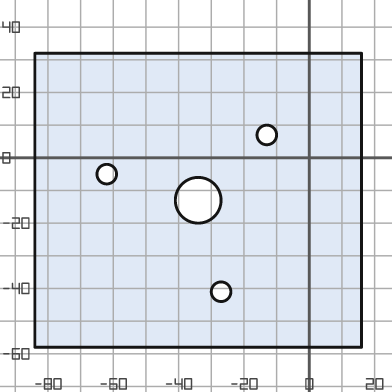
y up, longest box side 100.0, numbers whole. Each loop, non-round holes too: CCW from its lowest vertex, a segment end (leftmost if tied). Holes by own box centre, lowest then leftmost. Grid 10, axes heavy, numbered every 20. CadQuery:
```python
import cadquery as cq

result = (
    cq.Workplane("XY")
    .moveTo(-84.0, -58.0)
    .lineTo(16.0, -58.0)
    .lineTo(16.0, 32.0)
    .lineTo(-84.0, 32.0)
    .close()
    .moveTo(-27.0, -41.0)
    .circle(3.0)
    .moveTo(-34.0, -13.0)
    .circle(7.0)
    .moveTo(-62.0, -5.0)
    .circle(3.0)
    .moveTo(-13.0, 7.0)
    .circle(3.0)
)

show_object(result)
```